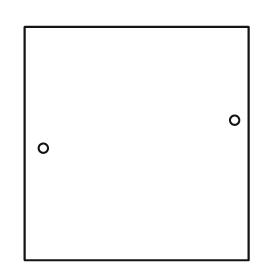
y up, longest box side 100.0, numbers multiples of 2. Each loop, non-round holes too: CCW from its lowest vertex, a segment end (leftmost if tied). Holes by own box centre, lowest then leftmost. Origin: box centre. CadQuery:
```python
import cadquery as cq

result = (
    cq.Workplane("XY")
    .moveTo(-48.0, -50.0)
    .lineTo(48.0, -50.0)
    .lineTo(48.0, 50.0)
    .lineTo(-48.0, 50.0)
    .close()
    .moveTo(-40.0, -2.0)
    .circle(2.0)
    .moveTo(42.0, 10.0)
    .circle(2.0)
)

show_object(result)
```